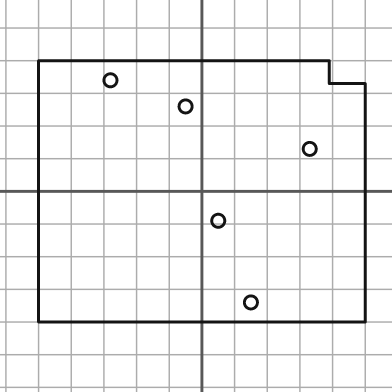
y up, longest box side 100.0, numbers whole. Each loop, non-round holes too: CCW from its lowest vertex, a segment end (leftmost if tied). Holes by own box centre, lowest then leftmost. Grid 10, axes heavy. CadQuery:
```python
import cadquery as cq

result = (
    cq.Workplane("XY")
    .moveTo(-50.0, -40.0)
    .lineTo(50.0, -40.0)
    .lineTo(50.0, 33.0)
    .lineTo(39.0, 33.0)
    .lineTo(39.0, 40.0)
    .lineTo(-50.0, 40.0)
    .close()
    .moveTo(15.0, -34.0)
    .circle(2.0)
    .moveTo(5.0, -9.0)
    .circle(2.0)
    .moveTo(33.0, 13.0)
    .circle(2.0)
    .moveTo(-5.0, 26.0)
    .circle(2.0)
    .moveTo(-28.0, 34.0)
    .circle(2.0)
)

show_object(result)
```